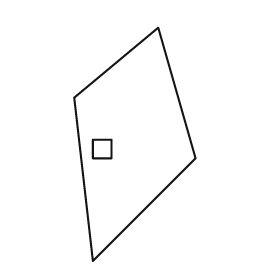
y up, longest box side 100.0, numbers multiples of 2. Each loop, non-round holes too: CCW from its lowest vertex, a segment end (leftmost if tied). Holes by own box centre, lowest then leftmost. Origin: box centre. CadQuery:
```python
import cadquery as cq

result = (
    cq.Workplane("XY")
    .moveTo(-18.0, -50.0)
    .lineTo(26.0, -6.0)
    .lineTo(10.0, 50.0)
    .lineTo(-26.0, 20.0)
    .close()
    .moveTo(-18.0, -6.0)
    .lineTo(-10.0, -6.0)
    .lineTo(-10.0, 2.0)
    .lineTo(-18.0, 2.0)
    .close()
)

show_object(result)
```